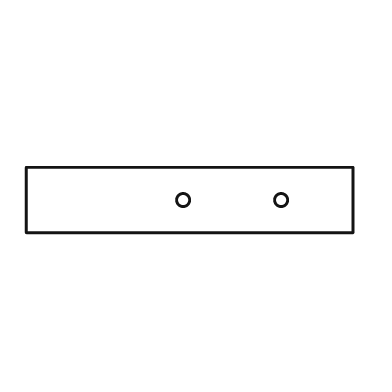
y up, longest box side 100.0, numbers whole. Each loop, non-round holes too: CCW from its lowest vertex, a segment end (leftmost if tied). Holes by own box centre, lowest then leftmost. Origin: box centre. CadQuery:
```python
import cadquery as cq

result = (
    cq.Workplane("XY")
    .moveTo(-50.0, -10.0)
    .lineTo(50.0, -10.0)
    .lineTo(50.0, 10.0)
    .lineTo(-50.0, 10.0)
    .close()
    .moveTo(-2.0, 0.0)
    .circle(2.0)
    .moveTo(28.0, 0.0)
    .circle(2.0)
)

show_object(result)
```